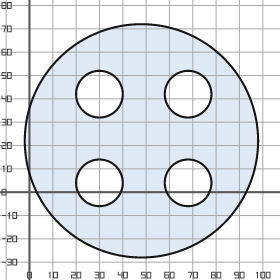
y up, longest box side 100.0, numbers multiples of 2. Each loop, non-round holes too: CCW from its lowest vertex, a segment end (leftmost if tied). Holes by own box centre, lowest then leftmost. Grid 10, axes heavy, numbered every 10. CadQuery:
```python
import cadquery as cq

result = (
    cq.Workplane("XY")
    .moveTo(48.0, 22.0)
    .circle(50.0)
    .moveTo(30.0, 4.0)
    .circle(10.0)
    .moveTo(68.0, 4.0)
    .circle(10.0)
    .moveTo(30.0, 42.0)
    .circle(10.0)
    .moveTo(68.0, 42.0)
    .circle(10.0)
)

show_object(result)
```